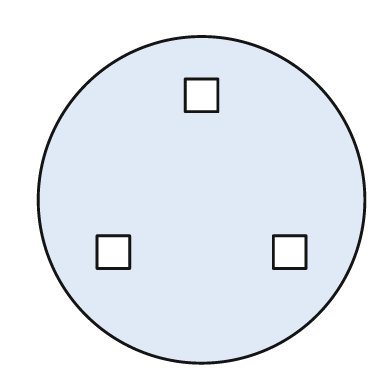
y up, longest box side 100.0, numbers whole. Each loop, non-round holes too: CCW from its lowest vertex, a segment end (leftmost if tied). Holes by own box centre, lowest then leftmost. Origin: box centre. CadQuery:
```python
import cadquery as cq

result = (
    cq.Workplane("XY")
    .moveTo(0.0, 0.0)
    .circle(50.0)
    .moveTo(-32.0, -21.0)
    .lineTo(-22.0, -21.0)
    .lineTo(-22.0, -11.0)
    .lineTo(-32.0, -11.0)
    .close()
    .moveTo(22.0, -21.0)
    .lineTo(32.0, -21.0)
    .lineTo(32.0, -11.0)
    .lineTo(22.0, -11.0)
    .close()
    .moveTo(-5.0, 27.0)
    .lineTo(5.0, 27.0)
    .lineTo(5.0, 37.0)
    .lineTo(-5.0, 37.0)
    .close()
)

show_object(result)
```